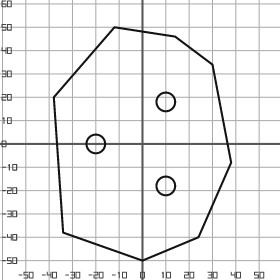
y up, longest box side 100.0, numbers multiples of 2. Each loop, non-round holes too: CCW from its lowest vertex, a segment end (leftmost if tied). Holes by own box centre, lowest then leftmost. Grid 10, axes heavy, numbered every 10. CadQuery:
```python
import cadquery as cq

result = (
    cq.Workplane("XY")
    .moveTo(0.0, -50.0)
    .lineTo(24.0, -40.0)
    .lineTo(38.0, -8.0)
    .lineTo(30.0, 34.0)
    .lineTo(14.0, 46.0)
    .lineTo(-12.0, 50.0)
    .lineTo(-38.0, 20.0)
    .lineTo(-34.0, -38.0)
    .close()
    .moveTo(10.0, -18.0)
    .circle(4.0)
    .moveTo(-20.0, 0.0)
    .circle(4.0)
    .moveTo(10.0, 18.0)
    .circle(4.0)
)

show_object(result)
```